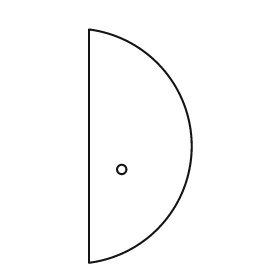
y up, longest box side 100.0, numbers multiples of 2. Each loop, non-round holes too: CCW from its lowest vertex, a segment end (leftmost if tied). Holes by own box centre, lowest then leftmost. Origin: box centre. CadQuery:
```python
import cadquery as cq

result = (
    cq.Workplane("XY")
    .moveTo(-22.0, -50.0)
    .threePointArc((22.0, 0.0), (-22.0, 50.0))
    .close()
    .moveTo(-8.0, -10.0)
    .circle(2.0)
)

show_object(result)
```